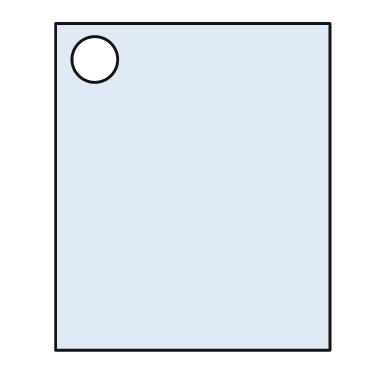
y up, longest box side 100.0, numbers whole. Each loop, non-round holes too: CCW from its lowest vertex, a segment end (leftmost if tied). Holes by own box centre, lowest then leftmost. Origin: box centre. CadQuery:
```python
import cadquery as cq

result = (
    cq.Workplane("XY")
    .moveTo(-42.0, -50.0)
    .lineTo(42.0, -50.0)
    .lineTo(42.0, 50.0)
    .lineTo(-42.0, 50.0)
    .close()
    .moveTo(-30.0, 39.0)
    .circle(7.0)
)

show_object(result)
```